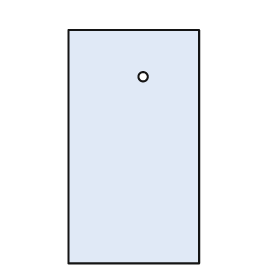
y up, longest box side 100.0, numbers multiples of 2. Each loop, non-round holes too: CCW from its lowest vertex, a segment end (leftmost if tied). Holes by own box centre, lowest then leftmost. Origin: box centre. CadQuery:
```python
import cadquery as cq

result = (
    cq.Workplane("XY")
    .moveTo(-28.0, -50.0)
    .lineTo(28.0, -50.0)
    .lineTo(28.0, 50.0)
    .lineTo(-28.0, 50.0)
    .close()
    .moveTo(4.0, 30.0)
    .circle(2.0)
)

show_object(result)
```